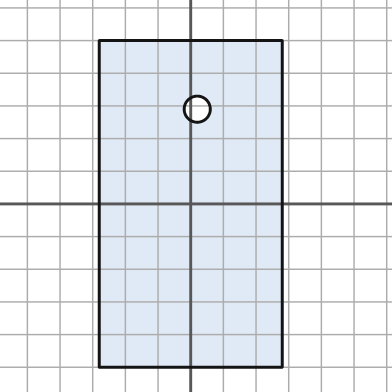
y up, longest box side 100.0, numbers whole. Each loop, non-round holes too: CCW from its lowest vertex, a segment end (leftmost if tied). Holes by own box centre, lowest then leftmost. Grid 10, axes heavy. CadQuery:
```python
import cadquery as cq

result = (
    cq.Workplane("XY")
    .moveTo(-28.0, -50.0)
    .lineTo(28.0, -50.0)
    .lineTo(28.0, 50.0)
    .lineTo(-28.0, 50.0)
    .close()
    .moveTo(2.0, 29.0)
    .circle(4.0)
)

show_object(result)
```